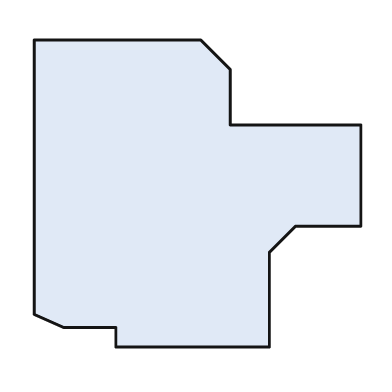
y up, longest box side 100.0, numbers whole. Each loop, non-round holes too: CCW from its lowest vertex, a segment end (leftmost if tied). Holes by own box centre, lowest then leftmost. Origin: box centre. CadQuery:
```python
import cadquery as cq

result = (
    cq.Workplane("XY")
    .moveTo(-25.0, -47.0)
    .lineTo(22.0, -47.0)
    .lineTo(22.0, -18.0)
    .lineTo(30.0, -10.0)
    .lineTo(50.0, -10.0)
    .lineTo(50.0, 21.0)
    .lineTo(10.0, 21.0)
    .lineTo(10.0, 38.0)
    .lineTo(1.0, 47.0)
    .lineTo(-50.0, 47.0)
    .lineTo(-50.0, -37.0)
    .lineTo(-41.0, -41.0)
    .lineTo(-25.0, -41.0)
    .close()
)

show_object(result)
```